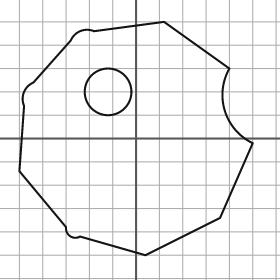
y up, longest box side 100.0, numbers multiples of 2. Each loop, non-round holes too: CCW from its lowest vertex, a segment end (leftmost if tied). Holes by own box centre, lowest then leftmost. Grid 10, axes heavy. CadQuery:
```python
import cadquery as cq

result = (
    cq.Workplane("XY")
    .moveTo(4.0, -50.0)
    .lineTo(36.0, -34.0)
    .lineTo(50.0, -2.0)
    .threePointArc((38.0, 12.0), (40.0, 30.0))
    .lineTo(12.0, 50.0)
    .lineTo(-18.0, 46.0)
    .threePointArc((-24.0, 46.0), (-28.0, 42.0))
    .lineTo(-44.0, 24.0)
    .threePointArc((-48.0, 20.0), (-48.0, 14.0))
    .lineTo(-50.0, -14.0)
    .lineTo(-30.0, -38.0)
    .threePointArc((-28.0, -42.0), (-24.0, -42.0))
    .close()
    .moveTo(-12.0, 20.0)
    .circle(10.0)
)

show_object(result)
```